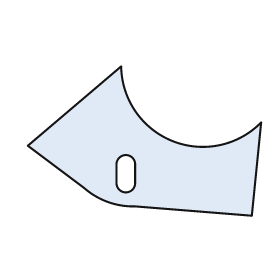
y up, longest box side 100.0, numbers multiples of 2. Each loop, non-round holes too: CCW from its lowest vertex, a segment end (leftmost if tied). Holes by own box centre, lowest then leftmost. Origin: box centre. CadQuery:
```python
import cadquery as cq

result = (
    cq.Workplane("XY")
    .moveTo(46.0, -32.0)
    .lineTo(50.0, 8.0)
    .threePointArc((12.0, 0.0), (-10.0, 32.0))
    .lineTo(-50.0, -2.0)
    .lineTo(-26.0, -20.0)
    .threePointArc((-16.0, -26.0), (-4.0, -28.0))
    .close()
    .moveTo(-12.0, -18.0)
    .threePointArc((-8.0, -22.0), (-4.0, -18.0))
    .lineTo(-4.0, -10.0)
    .threePointArc((-8.0, -6.0), (-12.0, -10.0))
    .close()
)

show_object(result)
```